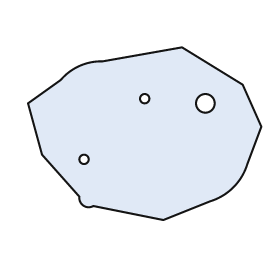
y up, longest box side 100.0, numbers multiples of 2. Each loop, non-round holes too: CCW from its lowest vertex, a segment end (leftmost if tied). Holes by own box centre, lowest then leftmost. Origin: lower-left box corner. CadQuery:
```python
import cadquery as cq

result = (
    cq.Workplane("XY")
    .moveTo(58.0, 0.0)
    .lineTo(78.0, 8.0)
    .threePointArc((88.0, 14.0), (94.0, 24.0))
    .lineTo(100.0, 40.0)
    .lineTo(92.0, 58.0)
    .lineTo(66.0, 74.0)
    .lineTo(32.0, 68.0)
    .threePointArc((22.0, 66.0), (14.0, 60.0))
    .lineTo(0.0, 50.0)
    .lineTo(6.0, 28.0)
    .lineTo(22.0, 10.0)
    .threePointArc((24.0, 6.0), (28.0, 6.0))
    .close()
    .moveTo(24.0, 26.0)
    .circle(2.0)
    .moveTo(76.0, 50.0)
    .circle(4.0)
    .moveTo(50.0, 52.0)
    .circle(2.0)
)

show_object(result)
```